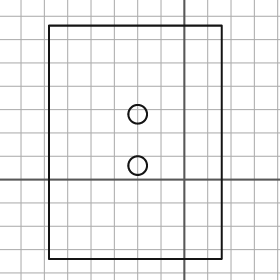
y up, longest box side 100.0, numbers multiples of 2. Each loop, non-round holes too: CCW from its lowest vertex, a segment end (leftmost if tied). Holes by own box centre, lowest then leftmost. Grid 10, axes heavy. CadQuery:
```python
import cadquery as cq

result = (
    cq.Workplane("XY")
    .moveTo(-58.0, -34.0)
    .lineTo(16.0, -34.0)
    .lineTo(16.0, 66.0)
    .lineTo(-58.0, 66.0)
    .close()
    .moveTo(-20.0, 6.0)
    .circle(4.0)
    .moveTo(-20.0, 28.0)
    .circle(4.0)
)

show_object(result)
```